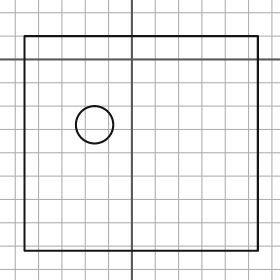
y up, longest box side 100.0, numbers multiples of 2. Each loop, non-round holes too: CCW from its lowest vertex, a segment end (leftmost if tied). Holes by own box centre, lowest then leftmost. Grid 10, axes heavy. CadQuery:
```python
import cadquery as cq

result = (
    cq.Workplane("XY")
    .moveTo(-46.0, -82.0)
    .lineTo(54.0, -82.0)
    .lineTo(54.0, 10.0)
    .lineTo(-46.0, 10.0)
    .close()
    .moveTo(-16.0, -28.0)
    .circle(8.0)
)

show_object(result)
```